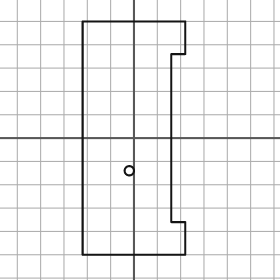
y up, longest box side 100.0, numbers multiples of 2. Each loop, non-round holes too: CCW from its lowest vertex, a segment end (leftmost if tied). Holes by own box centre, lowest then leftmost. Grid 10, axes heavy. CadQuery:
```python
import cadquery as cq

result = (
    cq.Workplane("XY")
    .moveTo(-22.0, -50.0)
    .lineTo(22.0, -50.0)
    .lineTo(22.0, -36.0)
    .lineTo(16.0, -36.0)
    .lineTo(16.0, 36.0)
    .lineTo(22.0, 36.0)
    .lineTo(22.0, 50.0)
    .lineTo(-22.0, 50.0)
    .close()
    .moveTo(-2.0, -14.0)
    .circle(2.0)
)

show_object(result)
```